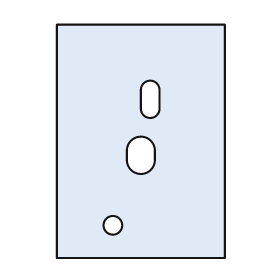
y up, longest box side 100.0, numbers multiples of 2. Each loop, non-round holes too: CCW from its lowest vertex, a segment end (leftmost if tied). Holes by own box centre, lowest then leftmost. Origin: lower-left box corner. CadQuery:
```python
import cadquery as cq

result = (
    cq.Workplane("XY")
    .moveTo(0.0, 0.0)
    .lineTo(72.0, 0.0)
    .lineTo(72.0, 100.0)
    .lineTo(0.0, 100.0)
    .close()
    .moveTo(24.0, 14.0)
    .circle(4.0)
    .moveTo(30.0, 42.0)
    .threePointArc((36.0, 36.0), (42.0, 42.0))
    .lineTo(42.0, 46.0)
    .threePointArc((36.0, 52.0), (30.0, 46.0))
    .close()
    .moveTo(36.0, 64.0)
    .threePointArc((40.0, 60.0), (44.0, 64.0))
    .lineTo(44.0, 72.0)
    .threePointArc((40.0, 76.0), (36.0, 72.0))
    .close()
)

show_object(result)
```